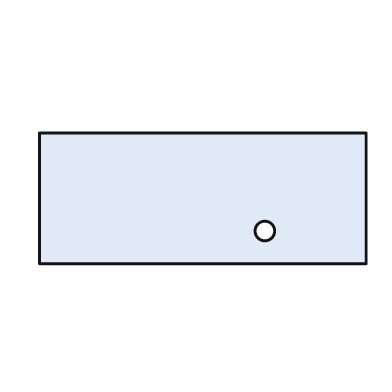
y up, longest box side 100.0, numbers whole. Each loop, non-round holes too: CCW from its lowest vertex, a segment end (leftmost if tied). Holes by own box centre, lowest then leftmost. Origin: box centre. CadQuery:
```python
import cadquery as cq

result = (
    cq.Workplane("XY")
    .moveTo(-50.0, -20.0)
    .lineTo(50.0, -20.0)
    .lineTo(50.0, 20.0)
    .lineTo(-50.0, 20.0)
    .close()
    .moveTo(19.0, -10.0)
    .circle(3.0)
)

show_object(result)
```